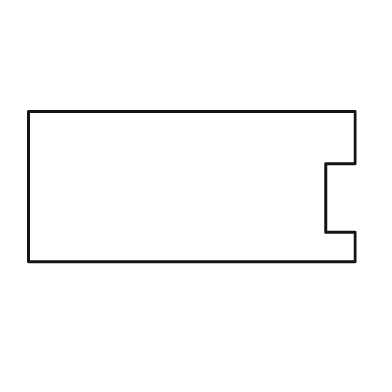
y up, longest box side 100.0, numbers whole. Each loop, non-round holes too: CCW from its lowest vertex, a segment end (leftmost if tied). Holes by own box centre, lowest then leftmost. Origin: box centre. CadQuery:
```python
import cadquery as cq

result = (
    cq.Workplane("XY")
    .moveTo(-50.0, -23.0)
    .lineTo(50.0, -23.0)
    .lineTo(50.0, -14.0)
    .lineTo(41.0, -14.0)
    .lineTo(41.0, 7.0)
    .lineTo(50.0, 7.0)
    .lineTo(50.0, 23.0)
    .lineTo(-50.0, 23.0)
    .close()
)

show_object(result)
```